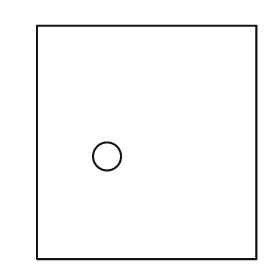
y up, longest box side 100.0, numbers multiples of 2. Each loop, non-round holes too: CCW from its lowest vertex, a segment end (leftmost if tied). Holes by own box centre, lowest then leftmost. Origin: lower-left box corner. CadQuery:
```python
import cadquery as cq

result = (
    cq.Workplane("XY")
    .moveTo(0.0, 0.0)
    .lineTo(94.0, 0.0)
    .lineTo(94.0, 100.0)
    .lineTo(0.0, 100.0)
    .close()
    .moveTo(30.0, 44.0)
    .circle(6.0)
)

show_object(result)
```